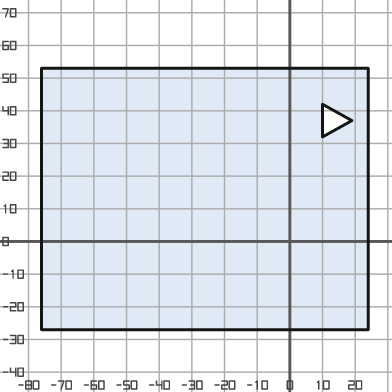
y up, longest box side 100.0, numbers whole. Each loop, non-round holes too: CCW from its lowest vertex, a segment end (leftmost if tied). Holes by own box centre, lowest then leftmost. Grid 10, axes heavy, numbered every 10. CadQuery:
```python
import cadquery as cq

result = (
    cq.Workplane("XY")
    .moveTo(-76.0, -27.0)
    .lineTo(24.0, -27.0)
    .lineTo(24.0, 53.0)
    .lineTo(-76.0, 53.0)
    .close()
    .moveTo(10.0, 32.0)
    .lineTo(19.0, 37.0)
    .lineTo(10.0, 42.0)
    .close()
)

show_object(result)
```